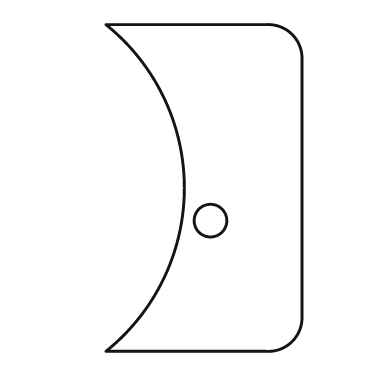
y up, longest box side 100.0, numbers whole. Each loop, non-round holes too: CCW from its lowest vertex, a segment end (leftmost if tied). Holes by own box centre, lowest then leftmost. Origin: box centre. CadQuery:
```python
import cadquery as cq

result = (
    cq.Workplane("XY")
    .moveTo(-30.0, -50.0)
    .lineTo(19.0, -50.0)
    .threePointArc((27.0, -47.0), (30.0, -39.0))
    .lineTo(30.0, 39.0)
    .threePointArc((27.0, 47.0), (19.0, 50.0))
    .lineTo(-30.0, 50.0)
    .threePointArc((-6.0, 0.0), (-30.0, -50.0))
    .close()
    .moveTo(2.0, -10.0)
    .circle(5.0)
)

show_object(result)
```